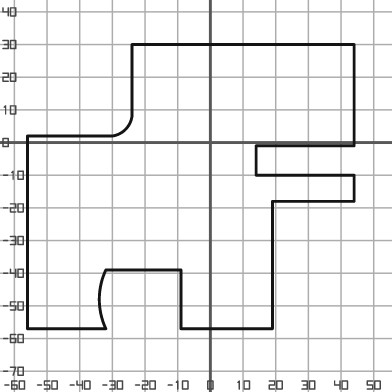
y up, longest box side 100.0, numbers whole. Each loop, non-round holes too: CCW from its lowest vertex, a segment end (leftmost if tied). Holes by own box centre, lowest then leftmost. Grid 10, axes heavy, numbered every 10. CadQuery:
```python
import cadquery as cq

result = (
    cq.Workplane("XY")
    .moveTo(-56.0, -57.0)
    .lineTo(-32.0, -57.0)
    .threePointArc((-34.0, -48.0), (-32.0, -39.0))
    .lineTo(-9.0, -39.0)
    .lineTo(-9.0, -57.0)
    .lineTo(19.0, -57.0)
    .lineTo(19.0, -18.0)
    .lineTo(44.0, -18.0)
    .lineTo(44.0, -10.0)
    .lineTo(14.0, -10.0)
    .lineTo(14.0, -1.0)
    .lineTo(44.0, -1.0)
    .lineTo(44.0, 30.0)
    .lineTo(-24.0, 30.0)
    .lineTo(-24.0, 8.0)
    .threePointArc((-26.0, 4.0), (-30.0, 2.0))
    .lineTo(-56.0, 2.0)
    .close()
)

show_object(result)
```